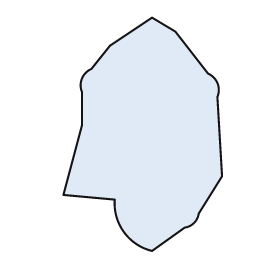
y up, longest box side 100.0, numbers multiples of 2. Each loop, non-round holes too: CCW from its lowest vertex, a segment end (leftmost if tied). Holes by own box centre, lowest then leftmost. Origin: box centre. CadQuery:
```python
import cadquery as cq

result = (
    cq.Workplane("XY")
    .moveTo(4.0, -50.0)
    .lineTo(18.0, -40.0)
    .threePointArc((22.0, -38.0), (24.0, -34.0))
    .lineTo(34.0, -18.0)
    .lineTo(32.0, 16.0)
    .threePointArc((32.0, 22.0), (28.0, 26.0))
    .lineTo(14.0, 44.0)
    .lineTo(4.0, 50.0)
    .lineTo(-14.0, 38.0)
    .lineTo(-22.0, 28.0)
    .threePointArc((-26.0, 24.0), (-26.0, 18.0))
    .lineTo(-26.0, 4.0)
    .lineTo(-34.0, -26.0)
    .lineTo(-12.0, -28.0)
    .threePointArc((-8.0, -42.0), (4.0, -50.0))
    .close()
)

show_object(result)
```